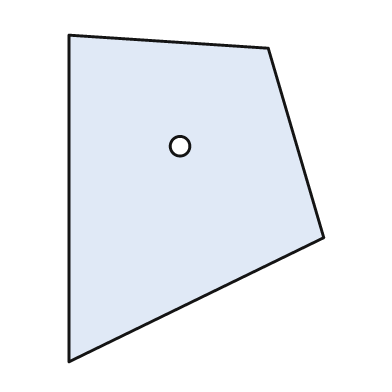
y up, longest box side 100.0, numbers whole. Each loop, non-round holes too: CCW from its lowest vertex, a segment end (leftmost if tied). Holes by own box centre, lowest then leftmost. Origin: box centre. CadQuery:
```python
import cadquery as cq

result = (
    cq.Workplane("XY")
    .moveTo(-39.0, -50.0)
    .lineTo(39.0, -12.0)
    .lineTo(22.0, 46.0)
    .lineTo(-39.0, 50.0)
    .close()
    .moveTo(-5.0, 16.0)
    .circle(3.0)
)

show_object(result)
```